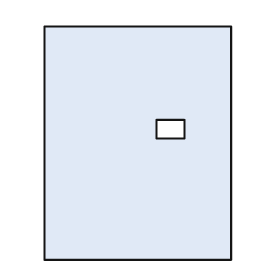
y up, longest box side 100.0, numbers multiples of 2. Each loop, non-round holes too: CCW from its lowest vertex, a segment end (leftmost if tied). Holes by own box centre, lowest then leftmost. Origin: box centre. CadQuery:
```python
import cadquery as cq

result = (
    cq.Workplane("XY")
    .moveTo(-40.0, -50.0)
    .lineTo(40.0, -50.0)
    .lineTo(40.0, 50.0)
    .lineTo(-40.0, 50.0)
    .close()
    .moveTo(8.0, 2.0)
    .lineTo(20.0, 2.0)
    .lineTo(20.0, 10.0)
    .lineTo(8.0, 10.0)
    .close()
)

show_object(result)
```